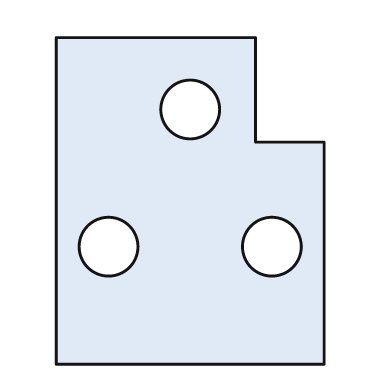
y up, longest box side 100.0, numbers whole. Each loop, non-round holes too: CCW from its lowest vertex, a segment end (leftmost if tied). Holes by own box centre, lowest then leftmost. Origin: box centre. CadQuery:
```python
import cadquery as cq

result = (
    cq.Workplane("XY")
    .moveTo(-41.0, -50.0)
    .lineTo(41.0, -50.0)
    .lineTo(41.0, 18.0)
    .lineTo(20.0, 18.0)
    .lineTo(20.0, 50.0)
    .lineTo(-41.0, 50.0)
    .close()
    .moveTo(-25.0, -14.0)
    .circle(9.0)
    .moveTo(25.0, -14.0)
    .circle(9.0)
    .moveTo(0.0, 28.0)
    .circle(9.0)
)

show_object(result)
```